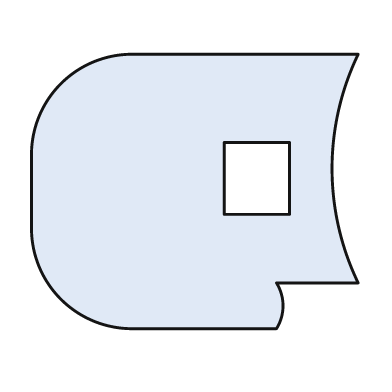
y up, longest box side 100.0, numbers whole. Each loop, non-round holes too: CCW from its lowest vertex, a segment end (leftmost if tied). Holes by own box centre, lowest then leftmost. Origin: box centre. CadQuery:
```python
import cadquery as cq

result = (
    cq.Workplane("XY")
    .moveTo(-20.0, -42.0)
    .lineTo(25.0, -42.0)
    .threePointArc((27.0, -35.0), (25.0, -28.0))
    .lineTo(50.0, -28.0)
    .threePointArc((42.0, 7.0), (50.0, 42.0))
    .lineTo(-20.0, 42.0)
    .threePointArc((-41.0, 33.0), (-50.0, 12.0))
    .lineTo(-50.0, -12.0)
    .threePointArc((-41.0, -33.0), (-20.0, -42.0))
    .close()
    .moveTo(9.0, -7.0)
    .lineTo(29.0, -7.0)
    .lineTo(29.0, 15.0)
    .lineTo(9.0, 15.0)
    .close()
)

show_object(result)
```